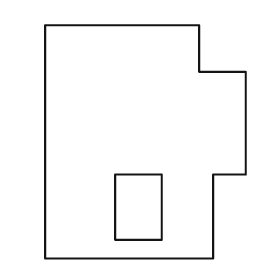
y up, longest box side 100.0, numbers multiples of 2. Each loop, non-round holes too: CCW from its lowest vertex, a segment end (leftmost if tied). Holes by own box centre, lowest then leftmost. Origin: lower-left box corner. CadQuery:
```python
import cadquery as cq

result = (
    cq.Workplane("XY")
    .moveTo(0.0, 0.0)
    .lineTo(72.0, 0.0)
    .lineTo(72.0, 36.0)
    .lineTo(86.0, 36.0)
    .lineTo(86.0, 80.0)
    .lineTo(66.0, 80.0)
    .lineTo(66.0, 100.0)
    .lineTo(0.0, 100.0)
    .close()
    .moveTo(30.0, 8.0)
    .lineTo(50.0, 8.0)
    .lineTo(50.0, 36.0)
    .lineTo(30.0, 36.0)
    .close()
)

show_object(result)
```